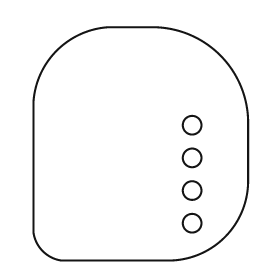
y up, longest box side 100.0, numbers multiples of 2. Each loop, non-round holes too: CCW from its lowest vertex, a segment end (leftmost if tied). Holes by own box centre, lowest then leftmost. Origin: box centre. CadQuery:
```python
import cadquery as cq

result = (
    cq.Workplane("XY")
    .moveTo(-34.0, -50.0)
    .lineTo(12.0, -50.0)
    .threePointArc((36.0, -40.0), (46.0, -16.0))
    .lineTo(46.0, 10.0)
    .threePointArc((34.0, 38.0), (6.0, 50.0))
    .lineTo(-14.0, 50.0)
    .threePointArc((-36.0, 40.0), (-46.0, 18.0))
    .lineTo(-46.0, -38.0)
    .threePointArc((-42.0, -46.0), (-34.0, -50.0))
    .close()
    .moveTo(22.0, -34.0)
    .circle(4.0)
    .moveTo(22.0, -20.0)
    .circle(4.0)
    .moveTo(22.0, -6.0)
    .circle(4.0)
    .moveTo(22.0, 8.0)
    .circle(4.0)
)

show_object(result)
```